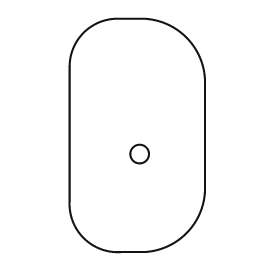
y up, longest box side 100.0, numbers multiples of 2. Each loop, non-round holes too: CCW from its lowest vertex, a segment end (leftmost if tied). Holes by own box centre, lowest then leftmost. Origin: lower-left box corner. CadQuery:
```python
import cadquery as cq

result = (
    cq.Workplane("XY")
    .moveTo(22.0, 0.0)
    .lineTo(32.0, 0.0)
    .threePointArc((50.0, 8.0), (58.0, 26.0))
    .lineTo(58.0, 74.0)
    .threePointArc((50.0, 92.0), (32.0, 100.0))
    .lineTo(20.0, 100.0)
    .threePointArc((6.0, 94.0), (0.0, 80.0))
    .lineTo(0.0, 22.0)
    .threePointArc((6.0, 6.0), (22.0, 0.0))
    .close()
    .moveTo(30.0, 42.0)
    .circle(4.0)
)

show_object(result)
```